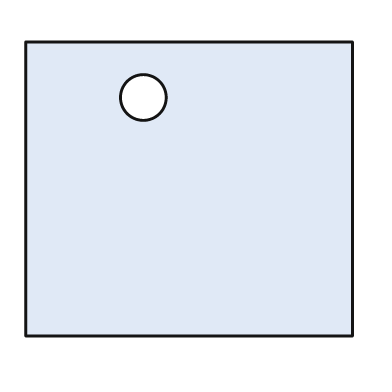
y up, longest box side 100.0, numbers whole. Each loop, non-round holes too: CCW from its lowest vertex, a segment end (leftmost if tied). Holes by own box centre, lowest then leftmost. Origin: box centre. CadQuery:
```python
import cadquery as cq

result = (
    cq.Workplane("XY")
    .moveTo(-50.0, -45.0)
    .lineTo(50.0, -45.0)
    .lineTo(50.0, 45.0)
    .lineTo(-50.0, 45.0)
    .close()
    .moveTo(-14.0, 28.0)
    .circle(7.0)
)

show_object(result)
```